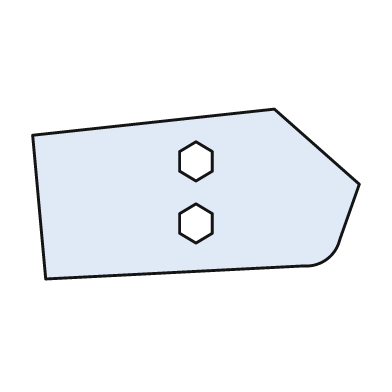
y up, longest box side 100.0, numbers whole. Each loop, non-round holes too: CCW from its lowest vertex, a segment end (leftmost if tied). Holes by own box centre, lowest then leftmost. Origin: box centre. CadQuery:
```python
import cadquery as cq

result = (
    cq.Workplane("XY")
    .moveTo(-46.0, -26.0)
    .lineTo(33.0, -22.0)
    .threePointArc((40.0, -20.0), (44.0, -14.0))
    .lineTo(50.0, 3.0)
    .lineTo(24.0, 26.0)
    .lineTo(-50.0, 18.0)
    .close()
    .moveTo(0.0, -15.0)
    .lineTo(5.0, -12.0)
    .lineTo(5.0, -6.0)
    .lineTo(0.0, -3.0)
    .lineTo(-5.0, -6.0)
    .lineTo(-5.0, -12.0)
    .close()
    .moveTo(0.0, 4.0)
    .lineTo(5.0, 7.0)
    .lineTo(5.0, 13.0)
    .lineTo(0.0, 16.0)
    .lineTo(-5.0, 13.0)
    .lineTo(-5.0, 7.0)
    .close()
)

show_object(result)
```